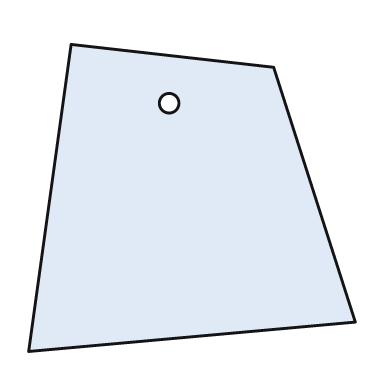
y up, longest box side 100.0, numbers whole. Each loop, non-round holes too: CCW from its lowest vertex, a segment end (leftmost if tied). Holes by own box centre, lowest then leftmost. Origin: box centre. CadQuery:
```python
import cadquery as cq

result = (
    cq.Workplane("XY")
    .moveTo(-50.0, -47.0)
    .lineTo(50.0, -38.0)
    .lineTo(25.0, 40.0)
    .lineTo(-37.0, 47.0)
    .close()
    .moveTo(-7.0, 29.0)
    .circle(3.0)
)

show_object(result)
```